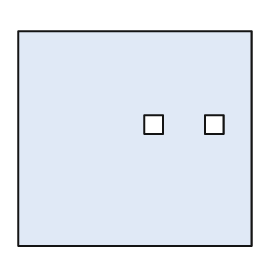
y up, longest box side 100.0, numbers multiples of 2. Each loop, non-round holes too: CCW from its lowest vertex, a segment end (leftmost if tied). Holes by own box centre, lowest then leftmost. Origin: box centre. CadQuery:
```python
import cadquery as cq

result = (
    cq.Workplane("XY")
    .moveTo(-50.0, -46.0)
    .lineTo(50.0, -46.0)
    .lineTo(50.0, 46.0)
    .lineTo(-50.0, 46.0)
    .close()
    .moveTo(4.0, 2.0)
    .lineTo(12.0, 2.0)
    .lineTo(12.0, 10.0)
    .lineTo(4.0, 10.0)
    .close()
    .moveTo(30.0, 2.0)
    .lineTo(38.0, 2.0)
    .lineTo(38.0, 10.0)
    .lineTo(30.0, 10.0)
    .close()
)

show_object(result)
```